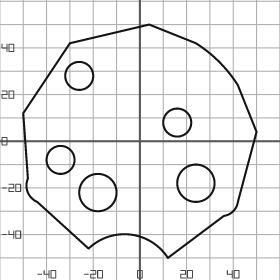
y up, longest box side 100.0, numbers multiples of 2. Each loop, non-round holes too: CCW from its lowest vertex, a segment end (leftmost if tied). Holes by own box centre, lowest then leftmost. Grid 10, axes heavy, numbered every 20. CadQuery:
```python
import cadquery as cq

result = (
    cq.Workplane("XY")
    .moveTo(12.0, -50.0)
    .lineTo(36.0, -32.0)
    .threePointArc((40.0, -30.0), (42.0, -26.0))
    .lineTo(50.0, 4.0)
    .lineTo(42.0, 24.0)
    .threePointArc((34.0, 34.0), (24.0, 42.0))
    .lineTo(4.0, 50.0)
    .lineTo(-30.0, 42.0)
    .lineTo(-50.0, 12.0)
    .lineTo(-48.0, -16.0)
    .threePointArc((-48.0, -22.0), (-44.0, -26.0))
    .lineTo(-22.0, -46.0)
    .threePointArc((-4.0, -40.0), (12.0, -50.0))
    .close()
    .moveTo(-18.0, -22.0)
    .circle(8.0)
    .moveTo(24.0, -18.0)
    .circle(8.0)
    .moveTo(-34.0, -8.0)
    .circle(6.0)
    .moveTo(16.0, 8.0)
    .circle(6.0)
    .moveTo(-26.0, 28.0)
    .circle(6.0)
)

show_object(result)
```